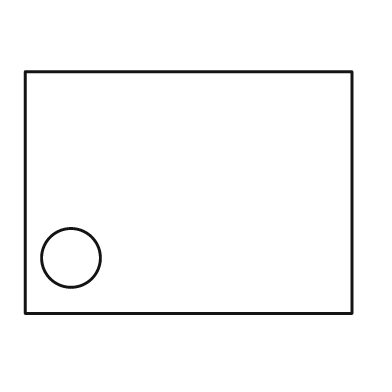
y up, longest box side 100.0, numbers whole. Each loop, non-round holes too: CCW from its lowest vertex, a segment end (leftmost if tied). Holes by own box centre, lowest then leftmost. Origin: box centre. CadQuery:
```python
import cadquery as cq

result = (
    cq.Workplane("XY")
    .moveTo(-50.0, -37.0)
    .lineTo(50.0, -37.0)
    .lineTo(50.0, 37.0)
    .lineTo(-50.0, 37.0)
    .close()
    .moveTo(-36.0, -20.0)
    .circle(9.0)
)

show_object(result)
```